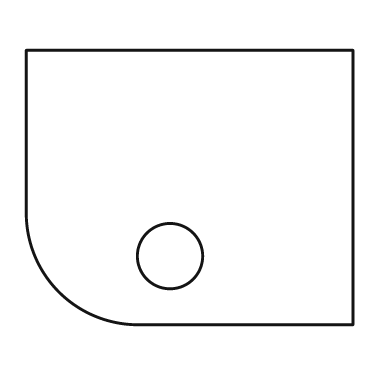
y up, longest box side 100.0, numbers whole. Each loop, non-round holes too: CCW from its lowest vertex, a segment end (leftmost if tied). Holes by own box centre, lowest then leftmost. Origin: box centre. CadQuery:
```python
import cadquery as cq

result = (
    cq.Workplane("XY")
    .moveTo(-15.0, -42.0)
    .lineTo(50.0, -42.0)
    .lineTo(50.0, 42.0)
    .lineTo(-50.0, 42.0)
    .lineTo(-50.0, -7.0)
    .threePointArc((-40.0, -32.0), (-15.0, -42.0))
    .close()
    .moveTo(-6.0, -21.0)
    .circle(10.0)
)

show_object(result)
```